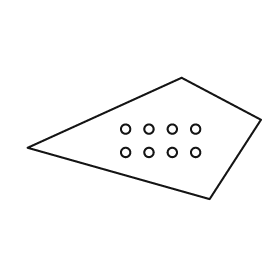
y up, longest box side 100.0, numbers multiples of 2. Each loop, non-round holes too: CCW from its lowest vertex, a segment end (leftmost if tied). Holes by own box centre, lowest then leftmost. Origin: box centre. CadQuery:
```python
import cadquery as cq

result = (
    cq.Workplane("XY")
    .moveTo(28.0, -26.0)
    .lineTo(50.0, 8.0)
    .lineTo(16.0, 26.0)
    .lineTo(-50.0, -4.0)
    .close()
    .moveTo(-8.0, -6.0)
    .circle(2.0)
    .moveTo(2.0, -6.0)
    .circle(2.0)
    .moveTo(12.0, -6.0)
    .circle(2.0)
    .moveTo(22.0, -6.0)
    .circle(2.0)
    .moveTo(-8.0, 4.0)
    .circle(2.0)
    .moveTo(2.0, 4.0)
    .circle(2.0)
    .moveTo(12.0, 4.0)
    .circle(2.0)
    .moveTo(22.0, 4.0)
    .circle(2.0)
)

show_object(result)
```